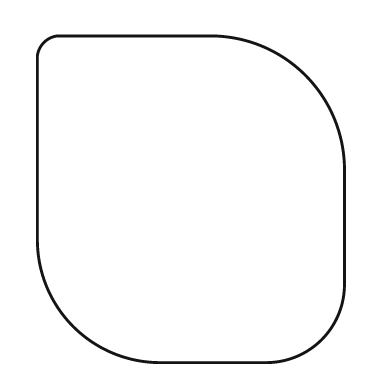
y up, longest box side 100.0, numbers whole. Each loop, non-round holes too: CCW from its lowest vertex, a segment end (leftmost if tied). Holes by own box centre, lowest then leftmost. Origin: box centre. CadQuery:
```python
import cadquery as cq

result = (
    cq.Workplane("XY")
    .moveTo(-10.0, -50.0)
    .lineTo(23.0, -50.0)
    .threePointArc((40.0, -43.0), (47.0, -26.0))
    .lineTo(47.0, 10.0)
    .threePointArc((35.0, 38.0), (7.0, 50.0))
    .lineTo(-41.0, 50.0)
    .threePointArc((-45.0, 48.0), (-47.0, 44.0))
    .lineTo(-47.0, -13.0)
    .threePointArc((-36.0, -39.0), (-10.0, -50.0))
    .close()
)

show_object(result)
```